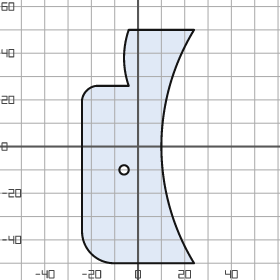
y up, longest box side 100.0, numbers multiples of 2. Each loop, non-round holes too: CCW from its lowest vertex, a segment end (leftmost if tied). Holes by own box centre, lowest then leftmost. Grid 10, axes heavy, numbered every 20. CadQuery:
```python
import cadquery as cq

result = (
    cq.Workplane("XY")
    .moveTo(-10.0, -50.0)
    .lineTo(24.0, -50.0)
    .threePointArc((10.0, 0.0), (24.0, 50.0))
    .lineTo(-4.0, 50.0)
    .threePointArc((-6.0, 38.0), (-4.0, 26.0))
    .lineTo(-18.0, 26.0)
    .threePointArc((-22.0, 24.0), (-24.0, 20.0))
    .lineTo(-24.0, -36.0)
    .threePointArc((-20.0, -46.0), (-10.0, -50.0))
    .close()
    .moveTo(-6.0, -10.0)
    .circle(2.0)
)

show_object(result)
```